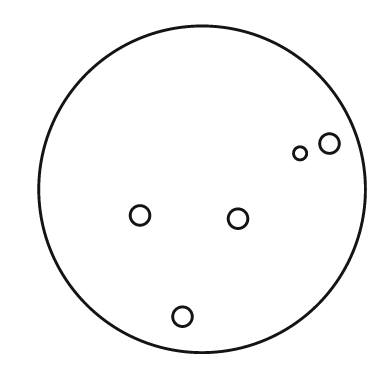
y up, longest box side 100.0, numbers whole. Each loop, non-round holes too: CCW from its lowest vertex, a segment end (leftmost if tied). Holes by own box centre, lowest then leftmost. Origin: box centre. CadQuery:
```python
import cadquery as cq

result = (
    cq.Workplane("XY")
    .moveTo(0.0, 0.0)
    .circle(50.0)
    .moveTo(-6.0, -39.0)
    .circle(3.0)
    .moveTo(11.0, -9.0)
    .circle(3.0)
    .moveTo(-19.0, -8.0)
    .circle(3.0)
    .moveTo(30.0, 11.0)
    .circle(2.0)
    .moveTo(39.0, 14.0)
    .circle(3.0)
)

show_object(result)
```